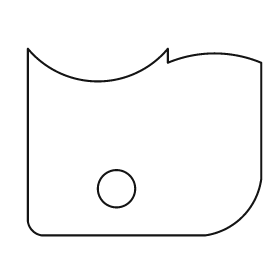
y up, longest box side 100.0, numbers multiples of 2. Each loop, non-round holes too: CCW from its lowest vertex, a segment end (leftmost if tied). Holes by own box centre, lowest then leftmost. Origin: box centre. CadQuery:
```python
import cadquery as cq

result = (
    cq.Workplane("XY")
    .moveTo(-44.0, -40.0)
    .lineTo(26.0, -40.0)
    .threePointArc((42.0, -32.0), (50.0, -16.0))
    .lineTo(50.0, 34.0)
    .threePointArc((30.0, 38.0), (10.0, 34.0))
    .lineTo(10.0, 40.0)
    .threePointArc((-20.0, 26.0), (-50.0, 40.0))
    .lineTo(-50.0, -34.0)
    .threePointArc((-48.0, -38.0), (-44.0, -40.0))
    .close()
    .moveTo(-12.0, -20.0)
    .circle(8.0)
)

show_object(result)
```